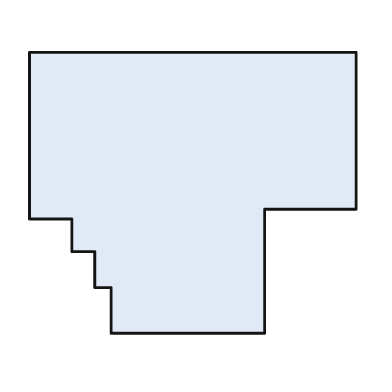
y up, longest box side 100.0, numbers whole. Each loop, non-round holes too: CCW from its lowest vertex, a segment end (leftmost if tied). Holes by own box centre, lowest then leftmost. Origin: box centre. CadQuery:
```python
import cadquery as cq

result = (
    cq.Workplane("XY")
    .moveTo(-25.0, -43.0)
    .lineTo(22.0, -43.0)
    .lineTo(22.0, -5.0)
    .lineTo(50.0, -5.0)
    .lineTo(50.0, 43.0)
    .lineTo(-50.0, 43.0)
    .lineTo(-50.0, -8.0)
    .lineTo(-37.0, -8.0)
    .lineTo(-37.0, -18.0)
    .lineTo(-30.0, -18.0)
    .lineTo(-30.0, -29.0)
    .lineTo(-25.0, -29.0)
    .close()
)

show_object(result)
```